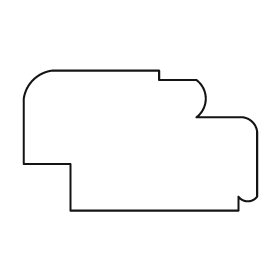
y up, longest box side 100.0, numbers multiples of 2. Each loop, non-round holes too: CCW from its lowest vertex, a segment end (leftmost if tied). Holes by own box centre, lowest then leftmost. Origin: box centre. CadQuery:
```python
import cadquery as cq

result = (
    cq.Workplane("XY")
    .moveTo(-30.0, -30.0)
    .lineTo(42.0, -30.0)
    .lineTo(42.0, -24.0)
    .threePointArc((46.0, -26.0), (50.0, -24.0))
    .lineTo(50.0, 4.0)
    .threePointArc((48.0, 8.0), (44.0, 10.0))
    .lineTo(24.0, 10.0)
    .threePointArc((28.0, 18.0), (24.0, 26.0))
    .lineTo(8.0, 26.0)
    .lineTo(8.0, 30.0)
    .lineTo(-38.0, 30.0)
    .threePointArc((-46.0, 26.0), (-50.0, 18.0))
    .lineTo(-50.0, -10.0)
    .lineTo(-30.0, -10.0)
    .close()
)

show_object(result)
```